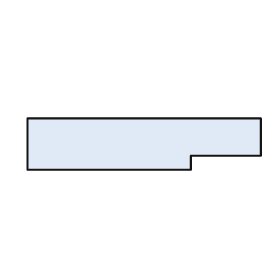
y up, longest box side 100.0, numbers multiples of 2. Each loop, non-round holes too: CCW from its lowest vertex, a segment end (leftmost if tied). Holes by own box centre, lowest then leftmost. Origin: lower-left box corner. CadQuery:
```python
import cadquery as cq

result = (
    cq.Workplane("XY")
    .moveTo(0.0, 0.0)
    .lineTo(70.0, 0.0)
    .lineTo(70.0, 6.0)
    .lineTo(100.0, 6.0)
    .lineTo(100.0, 22.0)
    .lineTo(0.0, 22.0)
    .close()
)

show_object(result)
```